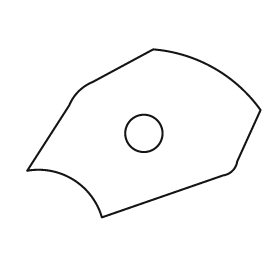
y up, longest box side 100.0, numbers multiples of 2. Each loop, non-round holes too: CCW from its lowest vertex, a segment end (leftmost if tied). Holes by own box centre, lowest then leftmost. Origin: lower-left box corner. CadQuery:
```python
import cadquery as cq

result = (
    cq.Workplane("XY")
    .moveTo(32.0, 0.0)
    .lineTo(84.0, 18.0)
    .threePointArc((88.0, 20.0), (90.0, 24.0))
    .lineTo(100.0, 46.0)
    .threePointArc((80.0, 64.0), (54.0, 72.0))
    .lineTo(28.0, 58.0)
    .threePointArc((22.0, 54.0), (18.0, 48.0))
    .lineTo(0.0, 20.0)
    .threePointArc((20.0, 16.0), (32.0, 0.0))
    .close()
    .moveTo(50.0, 36.0)
    .circle(8.0)
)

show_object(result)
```